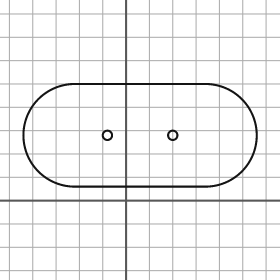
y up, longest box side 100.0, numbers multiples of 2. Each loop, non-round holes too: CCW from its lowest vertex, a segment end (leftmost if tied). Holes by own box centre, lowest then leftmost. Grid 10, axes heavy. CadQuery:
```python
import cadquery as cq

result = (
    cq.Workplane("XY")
    .moveTo(-22.0, 6.0)
    .lineTo(34.0, 6.0)
    .threePointArc((56.0, 28.0), (34.0, 50.0))
    .lineTo(-22.0, 50.0)
    .threePointArc((-44.0, 28.0), (-22.0, 6.0))
    .close()
    .moveTo(-8.0, 28.0)
    .circle(2.0)
    .moveTo(20.0, 28.0)
    .circle(2.0)
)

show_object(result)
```